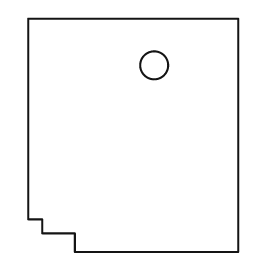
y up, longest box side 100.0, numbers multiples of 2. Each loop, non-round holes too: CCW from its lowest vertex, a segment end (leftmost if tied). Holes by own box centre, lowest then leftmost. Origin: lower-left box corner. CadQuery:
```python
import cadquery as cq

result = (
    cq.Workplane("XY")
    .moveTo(20.0, 0.0)
    .lineTo(90.0, 0.0)
    .lineTo(90.0, 100.0)
    .lineTo(0.0, 100.0)
    .lineTo(0.0, 14.0)
    .lineTo(6.0, 14.0)
    .lineTo(6.0, 8.0)
    .lineTo(20.0, 8.0)
    .close()
    .moveTo(54.0, 80.0)
    .circle(6.0)
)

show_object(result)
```